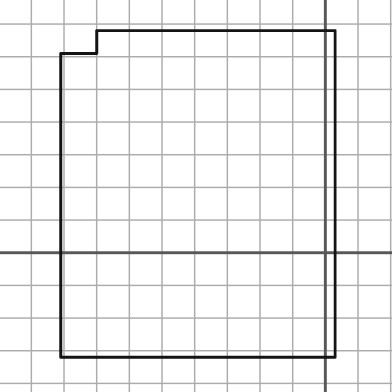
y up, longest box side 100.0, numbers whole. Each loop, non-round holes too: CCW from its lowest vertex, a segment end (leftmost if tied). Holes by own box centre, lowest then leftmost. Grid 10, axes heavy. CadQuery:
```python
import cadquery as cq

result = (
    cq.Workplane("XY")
    .moveTo(-81.0, -32.0)
    .lineTo(3.0, -32.0)
    .lineTo(3.0, 68.0)
    .lineTo(-70.0, 68.0)
    .lineTo(-70.0, 61.0)
    .lineTo(-81.0, 61.0)
    .close()
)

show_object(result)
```